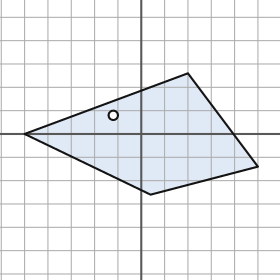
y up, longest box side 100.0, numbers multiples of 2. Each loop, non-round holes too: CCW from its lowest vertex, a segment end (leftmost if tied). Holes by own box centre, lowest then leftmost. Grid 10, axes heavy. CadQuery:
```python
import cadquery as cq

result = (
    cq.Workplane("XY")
    .moveTo(4.0, -26.0)
    .lineTo(50.0, -14.0)
    .lineTo(20.0, 26.0)
    .lineTo(-50.0, 0.0)
    .close()
    .moveTo(-12.0, 8.0)
    .circle(2.0)
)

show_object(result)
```